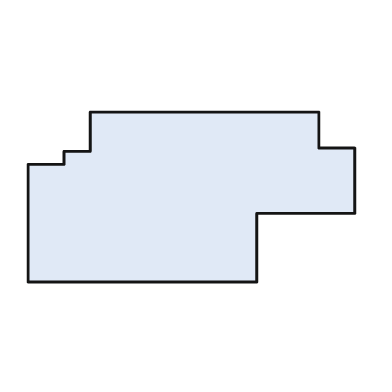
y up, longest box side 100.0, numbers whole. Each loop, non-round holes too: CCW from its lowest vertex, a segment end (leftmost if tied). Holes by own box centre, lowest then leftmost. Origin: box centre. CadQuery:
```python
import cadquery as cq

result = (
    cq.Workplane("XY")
    .moveTo(-50.0, -26.0)
    .lineTo(20.0, -26.0)
    .lineTo(20.0, -5.0)
    .lineTo(50.0, -5.0)
    .lineTo(50.0, 15.0)
    .lineTo(39.0, 15.0)
    .lineTo(39.0, 26.0)
    .lineTo(-31.0, 26.0)
    .lineTo(-31.0, 14.0)
    .lineTo(-39.0, 14.0)
    .lineTo(-39.0, 10.0)
    .lineTo(-50.0, 10.0)
    .close()
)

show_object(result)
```